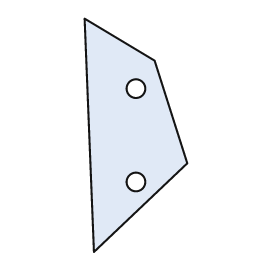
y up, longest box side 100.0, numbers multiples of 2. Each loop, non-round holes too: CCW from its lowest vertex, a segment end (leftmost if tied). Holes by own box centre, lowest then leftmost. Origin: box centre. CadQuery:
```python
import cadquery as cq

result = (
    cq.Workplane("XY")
    .moveTo(-18.0, -50.0)
    .lineTo(22.0, -12.0)
    .lineTo(8.0, 32.0)
    .lineTo(-22.0, 50.0)
    .close()
    .moveTo(0.0, -20.0)
    .circle(4.0)
    .moveTo(0.0, 20.0)
    .circle(4.0)
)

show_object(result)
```